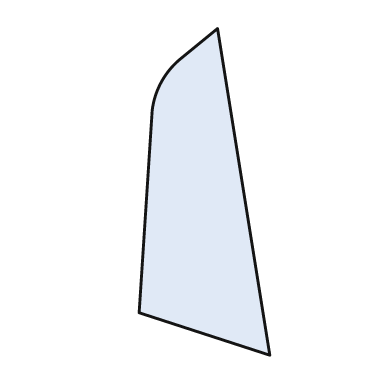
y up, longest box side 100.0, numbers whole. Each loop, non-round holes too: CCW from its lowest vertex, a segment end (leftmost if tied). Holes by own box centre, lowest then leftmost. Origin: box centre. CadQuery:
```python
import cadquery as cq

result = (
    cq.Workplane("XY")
    .moveTo(20.0, -50.0)
    .lineTo(4.0, 50.0)
    .lineTo(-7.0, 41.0)
    .threePointArc((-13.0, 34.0), (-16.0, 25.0))
    .lineTo(-20.0, -37.0)
    .close()
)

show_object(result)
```